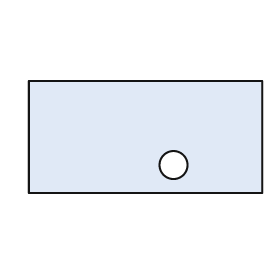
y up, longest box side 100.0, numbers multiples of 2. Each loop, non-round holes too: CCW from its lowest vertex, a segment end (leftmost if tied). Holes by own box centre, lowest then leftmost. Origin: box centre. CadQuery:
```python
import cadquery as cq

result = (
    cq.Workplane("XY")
    .moveTo(-50.0, -24.0)
    .lineTo(50.0, -24.0)
    .lineTo(50.0, 24.0)
    .lineTo(-50.0, 24.0)
    .close()
    .moveTo(12.0, -12.0)
    .circle(6.0)
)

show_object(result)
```